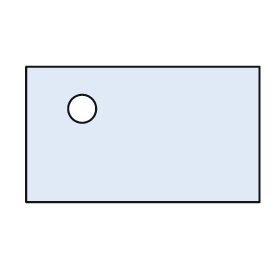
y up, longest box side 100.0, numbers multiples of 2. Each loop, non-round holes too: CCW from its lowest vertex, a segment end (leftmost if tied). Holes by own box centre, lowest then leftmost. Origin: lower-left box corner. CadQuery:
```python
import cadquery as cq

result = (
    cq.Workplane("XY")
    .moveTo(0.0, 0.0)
    .lineTo(100.0, 0.0)
    .lineTo(100.0, 58.0)
    .lineTo(0.0, 58.0)
    .close()
    .moveTo(24.0, 40.0)
    .circle(6.0)
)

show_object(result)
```